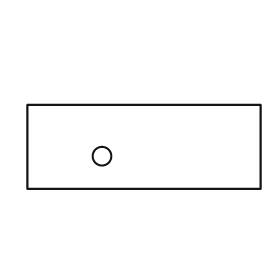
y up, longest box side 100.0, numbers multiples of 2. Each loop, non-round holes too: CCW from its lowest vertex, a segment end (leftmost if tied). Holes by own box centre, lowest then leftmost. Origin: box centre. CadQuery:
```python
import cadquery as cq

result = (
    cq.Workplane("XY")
    .moveTo(-50.0, -18.0)
    .lineTo(50.0, -18.0)
    .lineTo(50.0, 18.0)
    .lineTo(-50.0, 18.0)
    .close()
    .moveTo(-18.0, -4.0)
    .circle(4.0)
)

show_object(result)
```